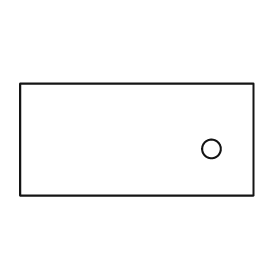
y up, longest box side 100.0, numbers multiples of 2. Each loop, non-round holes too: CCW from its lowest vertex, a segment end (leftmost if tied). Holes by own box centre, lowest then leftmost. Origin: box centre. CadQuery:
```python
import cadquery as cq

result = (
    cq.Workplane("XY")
    .moveTo(-50.0, -24.0)
    .lineTo(50.0, -24.0)
    .lineTo(50.0, 24.0)
    .lineTo(-50.0, 24.0)
    .close()
    .moveTo(32.0, -4.0)
    .circle(4.0)
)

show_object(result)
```